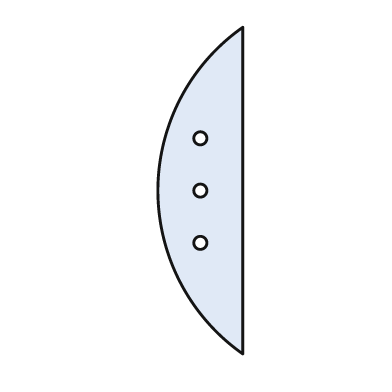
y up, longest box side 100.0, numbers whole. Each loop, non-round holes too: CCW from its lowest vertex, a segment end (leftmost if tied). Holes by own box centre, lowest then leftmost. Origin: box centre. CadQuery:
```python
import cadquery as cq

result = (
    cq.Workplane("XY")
    .moveTo(13.0, -50.0)
    .lineTo(13.0, 50.0)
    .threePointArc((-13.0, 0.0), (13.0, -50.0))
    .close()
    .moveTo(0.0, -16.0)
    .circle(2.0)
    .moveTo(0.0, 0.0)
    .circle(2.0)
    .moveTo(0.0, 16.0)
    .circle(2.0)
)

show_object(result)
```